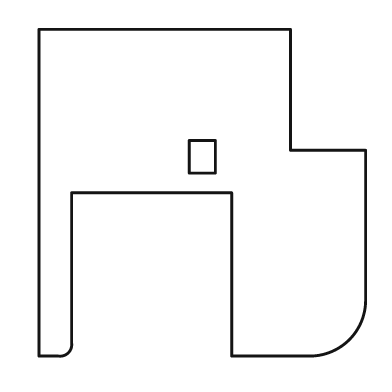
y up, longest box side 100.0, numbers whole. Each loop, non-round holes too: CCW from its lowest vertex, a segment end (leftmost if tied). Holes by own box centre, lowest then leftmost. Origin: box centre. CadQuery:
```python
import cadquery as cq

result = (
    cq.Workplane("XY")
    .moveTo(-50.0, -50.0)
    .lineTo(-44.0, -50.0)
    .threePointArc((-41.0, -49.0), (-40.0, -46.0))
    .lineTo(-40.0, 0.0)
    .lineTo(9.0, 0.0)
    .lineTo(9.0, -50.0)
    .lineTo(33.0, -50.0)
    .threePointArc((45.0, -45.0), (50.0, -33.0))
    .lineTo(50.0, 13.0)
    .lineTo(27.0, 13.0)
    .lineTo(27.0, 50.0)
    .lineTo(-50.0, 50.0)
    .close()
    .moveTo(-4.0, 6.0)
    .lineTo(4.0, 6.0)
    .lineTo(4.0, 16.0)
    .lineTo(-4.0, 16.0)
    .close()
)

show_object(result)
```